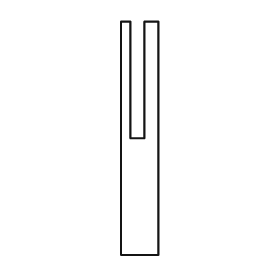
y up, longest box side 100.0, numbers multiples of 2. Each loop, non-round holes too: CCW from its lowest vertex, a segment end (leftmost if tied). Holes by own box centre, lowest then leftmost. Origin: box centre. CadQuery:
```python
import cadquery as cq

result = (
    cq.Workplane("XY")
    .moveTo(-8.0, -50.0)
    .lineTo(8.0, -50.0)
    .lineTo(8.0, 50.0)
    .lineTo(2.0, 50.0)
    .lineTo(2.0, 0.0)
    .lineTo(-4.0, 0.0)
    .lineTo(-4.0, 50.0)
    .lineTo(-8.0, 50.0)
    .close()
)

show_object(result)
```